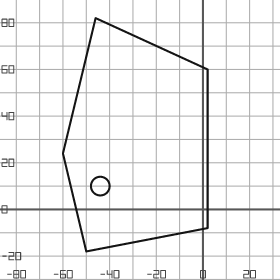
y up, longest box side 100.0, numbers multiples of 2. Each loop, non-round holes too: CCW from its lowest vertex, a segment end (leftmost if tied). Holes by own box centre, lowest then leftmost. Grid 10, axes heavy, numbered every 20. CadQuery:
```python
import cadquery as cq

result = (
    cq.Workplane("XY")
    .moveTo(-50.0, -18.0)
    .lineTo(2.0, -8.0)
    .lineTo(2.0, 60.0)
    .lineTo(-46.0, 82.0)
    .lineTo(-60.0, 24.0)
    .close()
    .moveTo(-44.0, 10.0)
    .circle(4.0)
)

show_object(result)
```